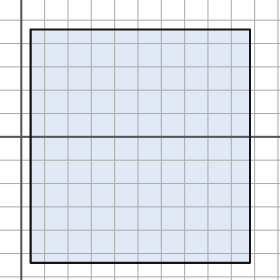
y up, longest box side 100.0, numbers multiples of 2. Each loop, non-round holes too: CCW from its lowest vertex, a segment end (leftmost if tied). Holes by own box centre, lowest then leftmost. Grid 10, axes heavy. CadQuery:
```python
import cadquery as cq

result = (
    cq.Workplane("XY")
    .moveTo(4.0, -54.0)
    .lineTo(98.0, -54.0)
    .lineTo(98.0, 46.0)
    .lineTo(4.0, 46.0)
    .close()
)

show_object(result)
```